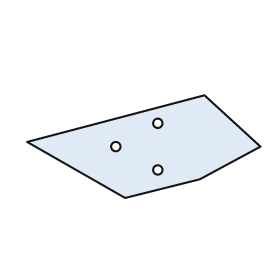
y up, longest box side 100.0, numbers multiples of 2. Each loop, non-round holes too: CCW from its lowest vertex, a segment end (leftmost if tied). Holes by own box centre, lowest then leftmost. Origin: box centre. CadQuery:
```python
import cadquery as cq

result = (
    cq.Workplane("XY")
    .moveTo(-8.0, -22.0)
    .lineTo(24.0, -14.0)
    .lineTo(50.0, 0.0)
    .lineTo(26.0, 22.0)
    .lineTo(-50.0, 2.0)
    .close()
    .moveTo(6.0, -10.0)
    .circle(2.0)
    .moveTo(-12.0, 0.0)
    .circle(2.0)
    .moveTo(6.0, 10.0)
    .circle(2.0)
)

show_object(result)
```